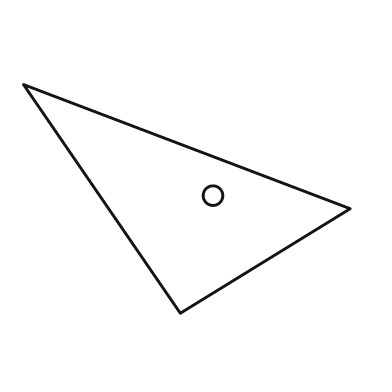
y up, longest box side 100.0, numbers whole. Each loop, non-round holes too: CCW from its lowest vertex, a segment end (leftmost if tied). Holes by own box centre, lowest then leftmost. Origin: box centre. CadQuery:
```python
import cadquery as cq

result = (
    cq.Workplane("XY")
    .moveTo(-2.0, -35.0)
    .lineTo(50.0, -3.0)
    .lineTo(-50.0, 35.0)
    .close()
    .moveTo(8.0, 1.0)
    .circle(3.0)
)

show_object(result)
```